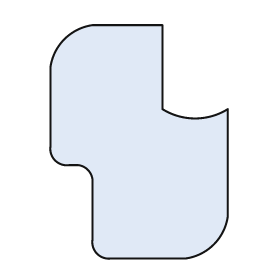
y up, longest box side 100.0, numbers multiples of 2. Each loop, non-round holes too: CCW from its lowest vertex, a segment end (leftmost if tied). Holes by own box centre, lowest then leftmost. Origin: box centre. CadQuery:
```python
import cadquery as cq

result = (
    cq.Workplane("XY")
    .moveTo(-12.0, -50.0)
    .lineTo(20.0, -50.0)
    .threePointArc((32.0, -44.0), (38.0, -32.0))
    .lineTo(38.0, 14.0)
    .threePointArc((24.0, 10.0), (10.0, 14.0))
    .lineTo(10.0, 50.0)
    .lineTo(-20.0, 50.0)
    .threePointArc((-32.0, 44.0), (-38.0, 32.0))
    .lineTo(-38.0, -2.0)
    .threePointArc((-36.0, -8.0), (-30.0, -10.0))
    .lineTo(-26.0, -10.0)
    .threePointArc((-22.0, -12.0), (-20.0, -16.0))
    .lineTo(-20.0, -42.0)
    .threePointArc((-18.0, -48.0), (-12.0, -50.0))
    .close()
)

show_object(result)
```